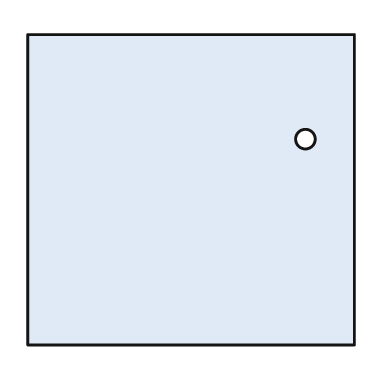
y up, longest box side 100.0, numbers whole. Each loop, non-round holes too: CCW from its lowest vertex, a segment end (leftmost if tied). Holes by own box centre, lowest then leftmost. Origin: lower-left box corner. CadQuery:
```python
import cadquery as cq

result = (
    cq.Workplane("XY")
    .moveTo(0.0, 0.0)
    .lineTo(100.0, 0.0)
    .lineTo(100.0, 95.0)
    .lineTo(0.0, 95.0)
    .close()
    .moveTo(85.0, 63.0)
    .circle(3.0)
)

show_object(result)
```